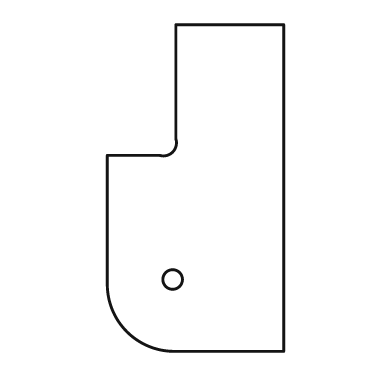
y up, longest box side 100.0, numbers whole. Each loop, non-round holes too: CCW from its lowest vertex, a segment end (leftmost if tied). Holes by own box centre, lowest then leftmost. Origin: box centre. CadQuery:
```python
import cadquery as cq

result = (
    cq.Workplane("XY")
    .moveTo(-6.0, -50.0)
    .lineTo(27.0, -50.0)
    .lineTo(27.0, 50.0)
    .lineTo(-6.0, 50.0)
    .lineTo(-6.0, 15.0)
    .threePointArc((-7.0, 11.0), (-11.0, 10.0))
    .lineTo(-27.0, 10.0)
    .lineTo(-27.0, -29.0)
    .threePointArc((-21.0, -44.0), (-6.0, -50.0))
    .close()
    .moveTo(-7.0, -28.0)
    .circle(3.0)
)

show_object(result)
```